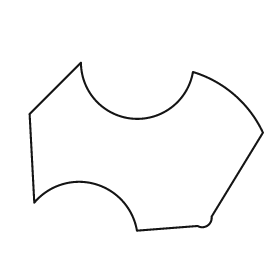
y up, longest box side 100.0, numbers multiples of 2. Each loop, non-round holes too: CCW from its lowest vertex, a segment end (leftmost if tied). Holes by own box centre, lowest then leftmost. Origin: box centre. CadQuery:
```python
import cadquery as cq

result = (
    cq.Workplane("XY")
    .moveTo(-4.0, -36.0)
    .lineTo(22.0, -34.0)
    .threePointArc((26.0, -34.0), (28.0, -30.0))
    .lineTo(50.0, 6.0)
    .threePointArc((38.0, 22.0), (20.0, 32.0))
    .threePointArc((-6.0, 12.0), (-28.0, 36.0))
    .lineTo(-50.0, 14.0)
    .lineTo(-48.0, -24.0)
    .threePointArc((-22.0, -16.0), (-4.0, -36.0))
    .close()
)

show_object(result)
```